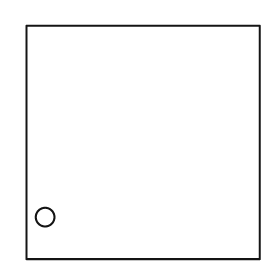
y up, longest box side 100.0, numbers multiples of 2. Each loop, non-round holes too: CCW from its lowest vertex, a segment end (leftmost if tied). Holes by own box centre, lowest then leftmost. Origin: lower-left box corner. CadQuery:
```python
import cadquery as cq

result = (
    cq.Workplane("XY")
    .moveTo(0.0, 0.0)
    .lineTo(100.0, 0.0)
    .lineTo(100.0, 100.0)
    .lineTo(0.0, 100.0)
    .close()
    .moveTo(8.0, 18.0)
    .circle(4.0)
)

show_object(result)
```